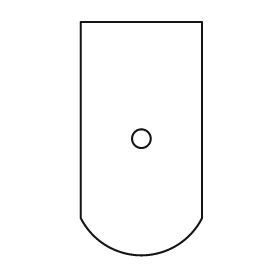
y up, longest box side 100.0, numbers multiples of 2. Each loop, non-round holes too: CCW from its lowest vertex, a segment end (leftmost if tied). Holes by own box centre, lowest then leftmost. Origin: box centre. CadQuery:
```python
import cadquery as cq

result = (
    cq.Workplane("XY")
    .moveTo(-26.0, -34.0)
    .threePointArc((0.0, -50.0), (26.0, -34.0))
    .lineTo(26.0, 50.0)
    .lineTo(-26.0, 50.0)
    .close()
    .moveTo(0.0, 0.0)
    .circle(4.0)
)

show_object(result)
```